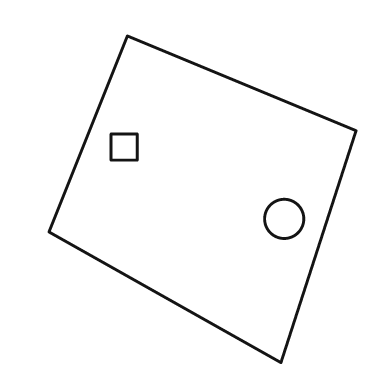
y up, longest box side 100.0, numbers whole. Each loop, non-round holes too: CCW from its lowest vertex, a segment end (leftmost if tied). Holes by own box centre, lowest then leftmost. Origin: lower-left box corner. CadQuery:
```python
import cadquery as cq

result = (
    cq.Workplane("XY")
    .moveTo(71.0, 0.0)
    .lineTo(94.0, 71.0)
    .lineTo(24.0, 100.0)
    .lineTo(0.0, 40.0)
    .close()
    .moveTo(72.0, 44.0)
    .circle(6.0)
    .moveTo(19.0, 62.0)
    .lineTo(27.0, 62.0)
    .lineTo(27.0, 70.0)
    .lineTo(19.0, 70.0)
    .close()
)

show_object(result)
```